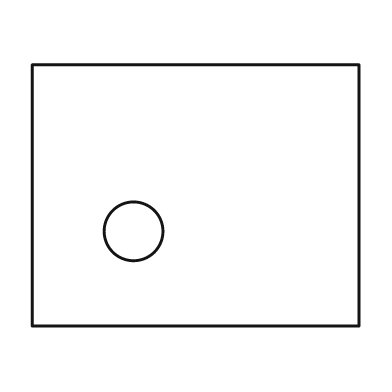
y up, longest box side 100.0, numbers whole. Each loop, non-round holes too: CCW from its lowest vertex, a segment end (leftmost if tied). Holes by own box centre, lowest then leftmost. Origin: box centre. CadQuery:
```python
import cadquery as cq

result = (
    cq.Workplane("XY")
    .moveTo(-50.0, -40.0)
    .lineTo(50.0, -40.0)
    .lineTo(50.0, 40.0)
    .lineTo(-50.0, 40.0)
    .close()
    .moveTo(-19.0, -11.0)
    .circle(9.0)
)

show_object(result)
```